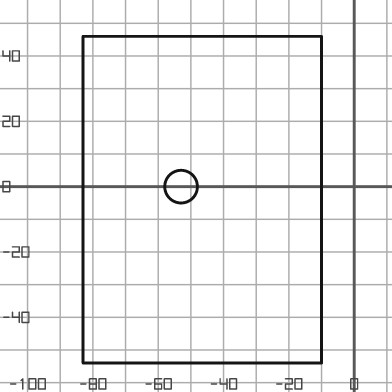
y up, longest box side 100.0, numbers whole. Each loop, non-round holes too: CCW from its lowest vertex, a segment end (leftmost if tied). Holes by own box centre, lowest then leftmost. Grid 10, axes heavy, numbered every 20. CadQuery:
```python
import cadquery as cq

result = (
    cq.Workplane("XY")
    .moveTo(-83.0, -54.0)
    .lineTo(-10.0, -54.0)
    .lineTo(-10.0, 46.0)
    .lineTo(-83.0, 46.0)
    .close()
    .moveTo(-53.0, 0.0)
    .circle(5.0)
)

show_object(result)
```